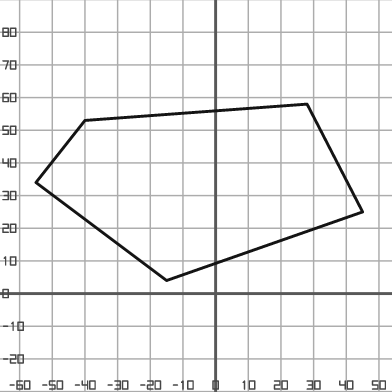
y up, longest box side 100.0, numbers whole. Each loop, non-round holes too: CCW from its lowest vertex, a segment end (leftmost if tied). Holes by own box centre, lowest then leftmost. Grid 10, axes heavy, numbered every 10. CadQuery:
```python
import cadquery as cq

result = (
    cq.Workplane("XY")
    .moveTo(-15.0, 4.0)
    .lineTo(45.0, 25.0)
    .lineTo(28.0, 58.0)
    .lineTo(-40.0, 53.0)
    .lineTo(-55.0, 34.0)
    .close()
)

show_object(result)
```